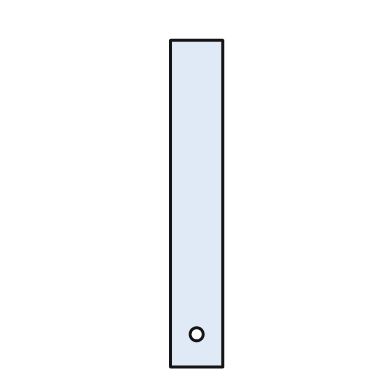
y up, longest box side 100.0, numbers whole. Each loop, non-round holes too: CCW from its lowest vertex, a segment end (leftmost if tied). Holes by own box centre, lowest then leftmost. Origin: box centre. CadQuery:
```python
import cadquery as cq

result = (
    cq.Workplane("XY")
    .moveTo(-8.0, -50.0)
    .lineTo(8.0, -50.0)
    .lineTo(8.0, 50.0)
    .lineTo(-8.0, 50.0)
    .close()
    .moveTo(0.0, -40.0)
    .circle(2.0)
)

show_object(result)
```